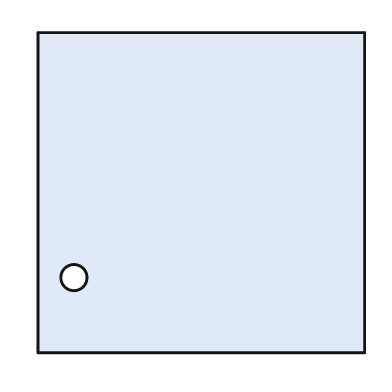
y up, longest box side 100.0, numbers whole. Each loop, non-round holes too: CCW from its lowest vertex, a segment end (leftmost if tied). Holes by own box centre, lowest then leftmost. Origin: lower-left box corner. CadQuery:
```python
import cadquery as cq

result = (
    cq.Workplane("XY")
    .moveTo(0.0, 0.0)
    .lineTo(100.0, 0.0)
    .lineTo(100.0, 98.0)
    .lineTo(0.0, 98.0)
    .close()
    .moveTo(11.0, 23.0)
    .circle(4.0)
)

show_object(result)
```